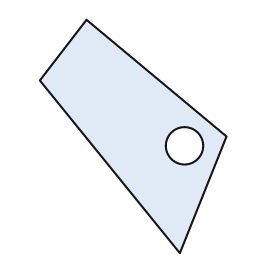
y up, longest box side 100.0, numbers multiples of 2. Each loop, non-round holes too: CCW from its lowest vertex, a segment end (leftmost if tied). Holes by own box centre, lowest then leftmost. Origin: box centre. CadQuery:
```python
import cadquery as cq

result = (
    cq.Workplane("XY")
    .moveTo(20.0, -50.0)
    .lineTo(40.0, 0.0)
    .lineTo(-20.0, 50.0)
    .lineTo(-40.0, 24.0)
    .close()
    .moveTo(22.0, -4.0)
    .circle(8.0)
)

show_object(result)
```